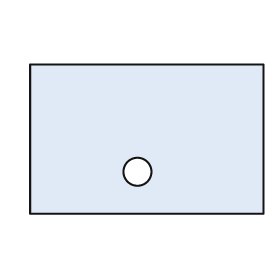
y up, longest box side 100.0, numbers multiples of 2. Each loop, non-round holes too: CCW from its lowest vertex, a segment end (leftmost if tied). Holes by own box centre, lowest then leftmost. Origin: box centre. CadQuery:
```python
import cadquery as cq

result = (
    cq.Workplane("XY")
    .moveTo(-50.0, -32.0)
    .lineTo(50.0, -32.0)
    .lineTo(50.0, 32.0)
    .lineTo(-50.0, 32.0)
    .close()
    .moveTo(-4.0, -14.0)
    .circle(6.0)
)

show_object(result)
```